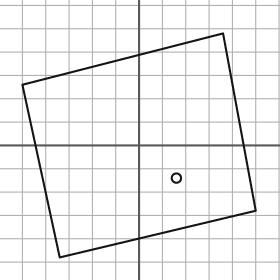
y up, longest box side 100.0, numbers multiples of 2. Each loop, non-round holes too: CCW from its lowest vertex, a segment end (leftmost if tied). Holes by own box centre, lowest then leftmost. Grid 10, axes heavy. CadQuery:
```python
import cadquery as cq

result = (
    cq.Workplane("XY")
    .moveTo(-34.0, -48.0)
    .lineTo(50.0, -28.0)
    .lineTo(36.0, 48.0)
    .lineTo(-50.0, 26.0)
    .close()
    .moveTo(16.0, -14.0)
    .circle(2.0)
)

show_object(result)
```